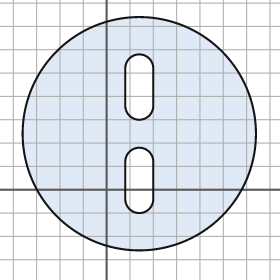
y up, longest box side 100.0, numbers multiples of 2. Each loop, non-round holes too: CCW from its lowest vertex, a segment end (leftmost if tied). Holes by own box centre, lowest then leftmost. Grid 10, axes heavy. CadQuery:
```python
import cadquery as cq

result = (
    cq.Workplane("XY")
    .moveTo(14.0, 24.0)
    .circle(50.0)
    .moveTo(8.0, -4.0)
    .threePointArc((14.0, -10.0), (20.0, -4.0))
    .lineTo(20.0, 12.0)
    .threePointArc((14.0, 18.0), (8.0, 12.0))
    .close()
    .moveTo(8.0, 36.0)
    .threePointArc((14.0, 30.0), (20.0, 36.0))
    .lineTo(20.0, 52.0)
    .threePointArc((14.0, 58.0), (8.0, 52.0))
    .close()
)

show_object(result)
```